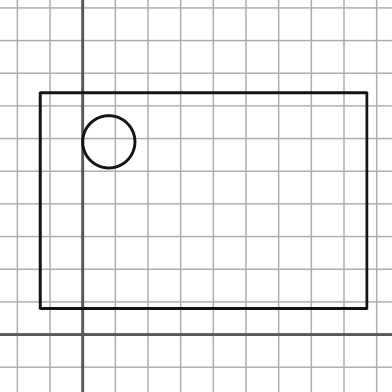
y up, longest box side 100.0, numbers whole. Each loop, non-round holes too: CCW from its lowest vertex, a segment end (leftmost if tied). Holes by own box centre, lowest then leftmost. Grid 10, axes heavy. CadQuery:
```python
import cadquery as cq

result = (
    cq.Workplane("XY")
    .moveTo(-13.0, 8.0)
    .lineTo(87.0, 8.0)
    .lineTo(87.0, 74.0)
    .lineTo(-13.0, 74.0)
    .close()
    .moveTo(8.0, 59.0)
    .circle(8.0)
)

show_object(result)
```